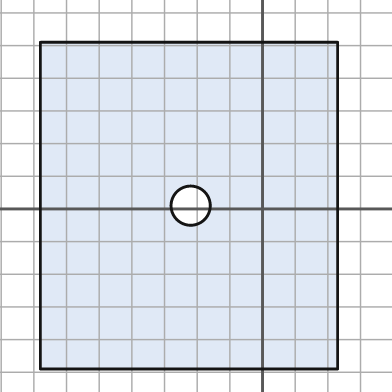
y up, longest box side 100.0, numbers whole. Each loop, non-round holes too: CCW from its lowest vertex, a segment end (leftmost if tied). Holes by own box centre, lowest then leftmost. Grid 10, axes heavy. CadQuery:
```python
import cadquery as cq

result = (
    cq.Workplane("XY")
    .moveTo(-68.0, -49.0)
    .lineTo(23.0, -49.0)
    .lineTo(23.0, 51.0)
    .lineTo(-68.0, 51.0)
    .close()
    .moveTo(-22.0, 1.0)
    .circle(6.0)
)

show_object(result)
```